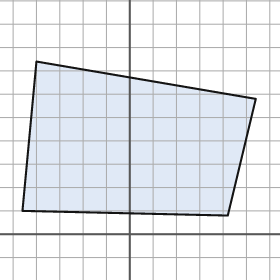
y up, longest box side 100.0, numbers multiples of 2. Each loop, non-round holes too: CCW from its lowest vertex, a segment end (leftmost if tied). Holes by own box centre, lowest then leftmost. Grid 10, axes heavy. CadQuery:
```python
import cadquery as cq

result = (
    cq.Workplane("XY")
    .moveTo(42.0, 8.0)
    .lineTo(54.0, 58.0)
    .lineTo(-40.0, 74.0)
    .lineTo(-46.0, 10.0)
    .close()
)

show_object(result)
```